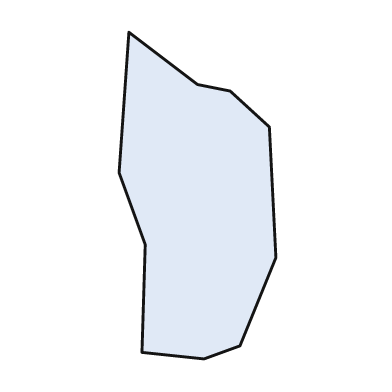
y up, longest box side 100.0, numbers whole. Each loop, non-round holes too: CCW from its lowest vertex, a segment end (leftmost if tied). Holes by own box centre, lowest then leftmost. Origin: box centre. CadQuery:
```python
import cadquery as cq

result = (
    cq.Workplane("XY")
    .moveTo(2.0, -50.0)
    .lineTo(13.0, -46.0)
    .lineTo(24.0, -19.0)
    .lineTo(22.0, 21.0)
    .lineTo(10.0, 32.0)
    .lineTo(0.0, 34.0)
    .lineTo(-21.0, 50.0)
    .lineTo(-24.0, 7.0)
    .lineTo(-16.0, -15.0)
    .lineTo(-17.0, -48.0)
    .close()
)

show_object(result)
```